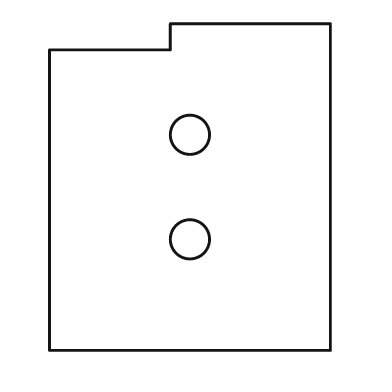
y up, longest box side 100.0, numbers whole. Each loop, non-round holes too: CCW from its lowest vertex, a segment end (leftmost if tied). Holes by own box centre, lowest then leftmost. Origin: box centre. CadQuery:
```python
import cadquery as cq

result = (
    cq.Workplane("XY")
    .moveTo(-43.0, -50.0)
    .lineTo(43.0, -50.0)
    .lineTo(43.0, 50.0)
    .lineTo(-6.0, 50.0)
    .lineTo(-6.0, 42.0)
    .lineTo(-43.0, 42.0)
    .close()
    .moveTo(0.0, -16.0)
    .circle(6.0)
    .moveTo(0.0, 16.0)
    .circle(6.0)
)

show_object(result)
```